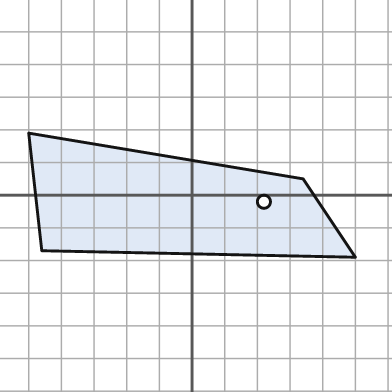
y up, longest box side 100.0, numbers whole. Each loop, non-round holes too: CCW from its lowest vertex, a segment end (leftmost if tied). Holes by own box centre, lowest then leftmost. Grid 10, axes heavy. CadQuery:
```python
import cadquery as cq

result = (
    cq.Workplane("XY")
    .moveTo(50.0, -19.0)
    .lineTo(34.0, 5.0)
    .lineTo(-50.0, 19.0)
    .lineTo(-46.0, -17.0)
    .close()
    .moveTo(22.0, -2.0)
    .circle(2.0)
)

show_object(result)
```